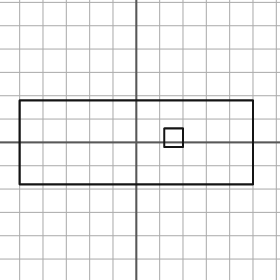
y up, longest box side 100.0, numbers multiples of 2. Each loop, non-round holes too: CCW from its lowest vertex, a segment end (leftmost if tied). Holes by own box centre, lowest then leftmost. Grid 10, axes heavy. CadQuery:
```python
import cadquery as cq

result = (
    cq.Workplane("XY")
    .moveTo(-50.0, -18.0)
    .lineTo(50.0, -18.0)
    .lineTo(50.0, 18.0)
    .lineTo(-50.0, 18.0)
    .close()
    .moveTo(12.0, -2.0)
    .lineTo(20.0, -2.0)
    .lineTo(20.0, 6.0)
    .lineTo(12.0, 6.0)
    .close()
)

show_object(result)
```